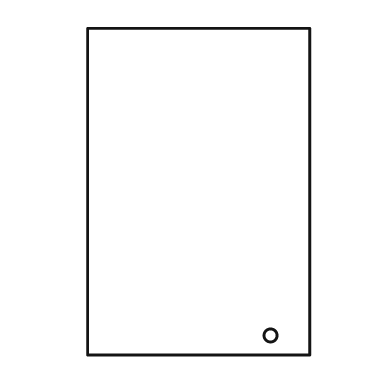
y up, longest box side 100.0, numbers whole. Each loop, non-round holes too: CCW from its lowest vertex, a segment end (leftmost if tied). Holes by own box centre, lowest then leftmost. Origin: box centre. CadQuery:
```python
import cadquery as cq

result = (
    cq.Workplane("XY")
    .moveTo(-34.0, -50.0)
    .lineTo(34.0, -50.0)
    .lineTo(34.0, 50.0)
    .lineTo(-34.0, 50.0)
    .close()
    .moveTo(22.0, -44.0)
    .circle(2.0)
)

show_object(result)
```